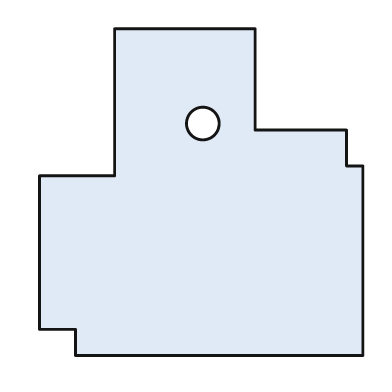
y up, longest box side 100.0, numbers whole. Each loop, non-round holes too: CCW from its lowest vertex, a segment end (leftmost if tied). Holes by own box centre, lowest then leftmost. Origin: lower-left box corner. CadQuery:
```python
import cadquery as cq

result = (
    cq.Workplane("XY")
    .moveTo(11.0, 0.0)
    .lineTo(99.0, 0.0)
    .lineTo(99.0, 58.0)
    .lineTo(94.0, 58.0)
    .lineTo(94.0, 69.0)
    .lineTo(66.0, 69.0)
    .lineTo(66.0, 100.0)
    .lineTo(23.0, 100.0)
    .lineTo(23.0, 55.0)
    .lineTo(0.0, 55.0)
    .lineTo(0.0, 8.0)
    .lineTo(11.0, 8.0)
    .close()
    .moveTo(50.0, 71.0)
    .circle(5.0)
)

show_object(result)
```